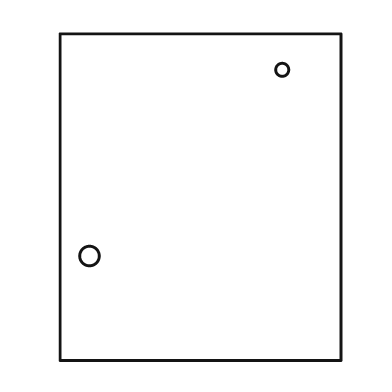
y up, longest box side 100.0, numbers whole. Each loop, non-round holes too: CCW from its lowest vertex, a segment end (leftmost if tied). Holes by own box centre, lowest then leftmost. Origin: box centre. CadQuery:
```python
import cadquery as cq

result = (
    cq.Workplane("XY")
    .moveTo(-43.0, -50.0)
    .lineTo(43.0, -50.0)
    .lineTo(43.0, 50.0)
    .lineTo(-43.0, 50.0)
    .close()
    .moveTo(-34.0, -18.0)
    .circle(3.0)
    .moveTo(25.0, 39.0)
    .circle(2.0)
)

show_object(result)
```